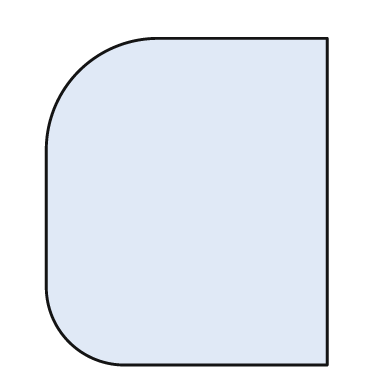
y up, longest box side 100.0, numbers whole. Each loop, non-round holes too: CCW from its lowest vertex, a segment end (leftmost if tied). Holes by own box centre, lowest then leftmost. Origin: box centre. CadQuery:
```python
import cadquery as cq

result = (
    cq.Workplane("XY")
    .moveTo(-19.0, -50.0)
    .lineTo(43.0, -50.0)
    .lineTo(43.0, 50.0)
    .lineTo(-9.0, 50.0)
    .threePointArc((-33.0, 40.0), (-43.0, 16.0))
    .lineTo(-43.0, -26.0)
    .threePointArc((-36.0, -43.0), (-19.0, -50.0))
    .close()
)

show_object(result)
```